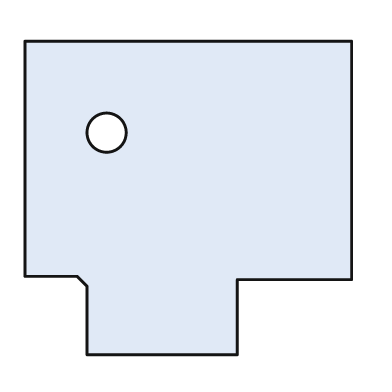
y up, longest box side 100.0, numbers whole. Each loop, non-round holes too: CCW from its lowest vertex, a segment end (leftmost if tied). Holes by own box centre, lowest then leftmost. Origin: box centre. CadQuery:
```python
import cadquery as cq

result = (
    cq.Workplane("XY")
    .moveTo(-31.0, -48.0)
    .lineTo(15.0, -48.0)
    .lineTo(15.0, -25.0)
    .lineTo(50.0, -25.0)
    .lineTo(50.0, 48.0)
    .lineTo(-50.0, 48.0)
    .lineTo(-50.0, -24.0)
    .lineTo(-34.0, -24.0)
    .lineTo(-31.0, -27.0)
    .close()
    .moveTo(-25.0, 20.0)
    .circle(6.0)
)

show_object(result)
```